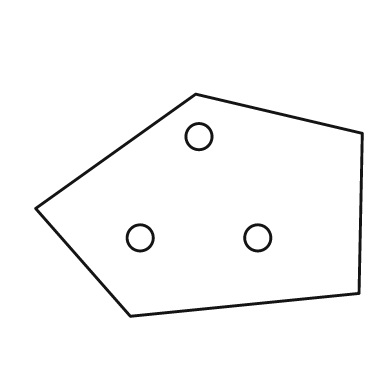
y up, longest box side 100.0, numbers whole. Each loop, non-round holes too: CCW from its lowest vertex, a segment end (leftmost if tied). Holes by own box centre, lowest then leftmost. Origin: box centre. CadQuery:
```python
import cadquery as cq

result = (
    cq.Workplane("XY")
    .moveTo(-21.0, -34.0)
    .lineTo(49.0, -27.0)
    .lineTo(50.0, 22.0)
    .lineTo(-1.0, 34.0)
    .lineTo(-50.0, -1.0)
    .close()
    .moveTo(-18.0, -10.0)
    .circle(4.0)
    .moveTo(18.0, -10.0)
    .circle(4.0)
    .moveTo(0.0, 21.0)
    .circle(4.0)
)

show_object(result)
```